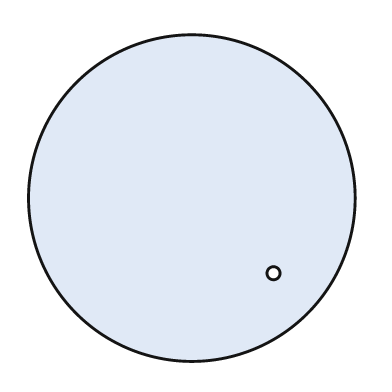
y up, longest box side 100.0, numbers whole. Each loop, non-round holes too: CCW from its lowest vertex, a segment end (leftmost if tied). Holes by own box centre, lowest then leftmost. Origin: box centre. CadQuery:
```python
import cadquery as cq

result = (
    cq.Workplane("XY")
    .moveTo(0.0, 0.0)
    .circle(50.0)
    .moveTo(25.0, -23.0)
    .circle(2.0)
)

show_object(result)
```